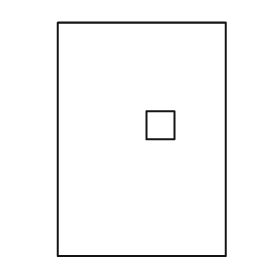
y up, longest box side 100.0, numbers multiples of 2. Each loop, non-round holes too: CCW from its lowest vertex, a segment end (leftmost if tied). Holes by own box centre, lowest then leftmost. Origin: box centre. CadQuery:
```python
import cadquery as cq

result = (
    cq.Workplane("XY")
    .moveTo(-36.0, -50.0)
    .lineTo(36.0, -50.0)
    .lineTo(36.0, 50.0)
    .lineTo(-36.0, 50.0)
    .close()
    .moveTo(2.0, 0.0)
    .lineTo(14.0, 0.0)
    .lineTo(14.0, 12.0)
    .lineTo(2.0, 12.0)
    .close()
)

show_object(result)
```